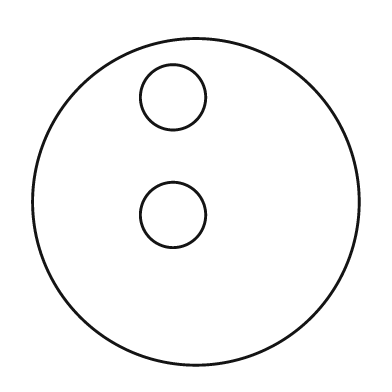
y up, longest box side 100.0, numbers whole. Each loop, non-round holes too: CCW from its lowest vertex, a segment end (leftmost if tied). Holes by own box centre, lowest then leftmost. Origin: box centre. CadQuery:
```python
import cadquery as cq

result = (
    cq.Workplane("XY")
    .moveTo(0.0, 0.0)
    .circle(50.0)
    .moveTo(-7.0, -4.0)
    .circle(10.0)
    .moveTo(-7.0, 32.0)
    .circle(10.0)
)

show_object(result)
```